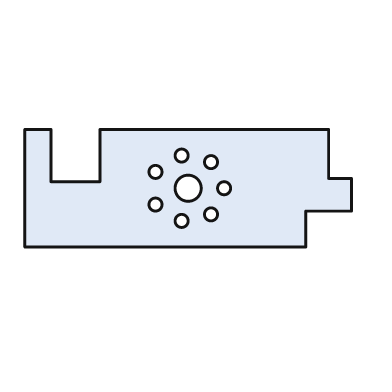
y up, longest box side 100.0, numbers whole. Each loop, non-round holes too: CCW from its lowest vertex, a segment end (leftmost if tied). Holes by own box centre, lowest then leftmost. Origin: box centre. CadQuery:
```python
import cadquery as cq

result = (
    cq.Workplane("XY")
    .moveTo(-50.0, -18.0)
    .lineTo(36.0, -18.0)
    .lineTo(36.0, -7.0)
    .lineTo(50.0, -7.0)
    .lineTo(50.0, 3.0)
    .lineTo(43.0, 3.0)
    .lineTo(43.0, 18.0)
    .lineTo(-27.0, 18.0)
    .lineTo(-27.0, 2.0)
    .lineTo(-42.0, 2.0)
    .lineTo(-42.0, 18.0)
    .lineTo(-50.0, 18.0)
    .close()
    .moveTo(-2.0, -10.0)
    .circle(2.0)
    .moveTo(7.0, -8.0)
    .circle(2.0)
    .moveTo(-10.0, -5.0)
    .circle(2.0)
    .moveTo(0.0, 0.0)
    .circle(4.0)
    .moveTo(11.0, 0.0)
    .circle(2.0)
    .moveTo(-10.0, 5.0)
    .circle(2.0)
    .moveTo(7.0, 8.0)
    .circle(2.0)
    .moveTo(-2.0, 10.0)
    .circle(2.0)
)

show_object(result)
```